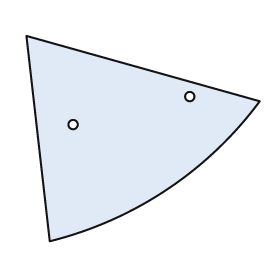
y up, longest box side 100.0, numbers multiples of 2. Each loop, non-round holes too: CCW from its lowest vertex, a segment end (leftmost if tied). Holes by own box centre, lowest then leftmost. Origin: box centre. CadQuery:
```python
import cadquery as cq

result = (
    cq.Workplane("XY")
    .moveTo(-40.0, -44.0)
    .threePointArc((10.0, -22.0), (50.0, 16.0))
    .lineTo(-50.0, 44.0)
    .close()
    .moveTo(-30.0, 6.0)
    .circle(2.0)
    .moveTo(20.0, 18.0)
    .circle(2.0)
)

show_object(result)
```